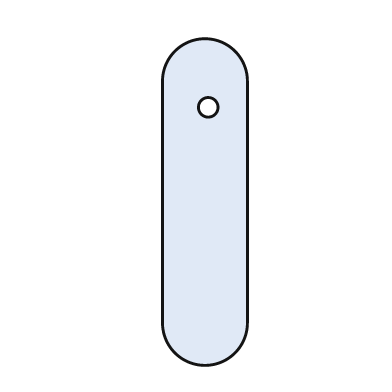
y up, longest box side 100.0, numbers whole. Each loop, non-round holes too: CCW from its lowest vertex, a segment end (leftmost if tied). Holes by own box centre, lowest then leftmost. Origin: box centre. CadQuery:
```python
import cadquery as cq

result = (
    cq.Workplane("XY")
    .moveTo(-13.0, -37.0)
    .threePointArc((0.0, -50.0), (13.0, -37.0))
    .lineTo(13.0, 37.0)
    .threePointArc((0.0, 50.0), (-13.0, 37.0))
    .close()
    .moveTo(1.0, 29.0)
    .circle(3.0)
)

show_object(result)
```